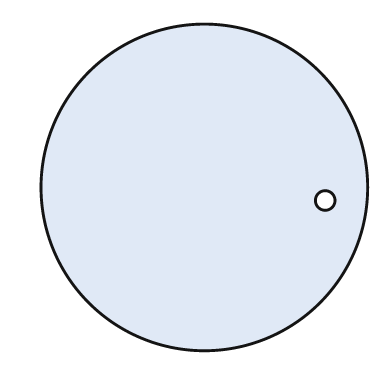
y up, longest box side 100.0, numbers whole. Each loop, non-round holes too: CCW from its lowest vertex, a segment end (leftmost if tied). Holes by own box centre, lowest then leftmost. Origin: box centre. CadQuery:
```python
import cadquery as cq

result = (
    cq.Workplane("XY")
    .moveTo(0.0, 0.0)
    .circle(50.0)
    .moveTo(37.0, -4.0)
    .circle(3.0)
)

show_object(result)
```